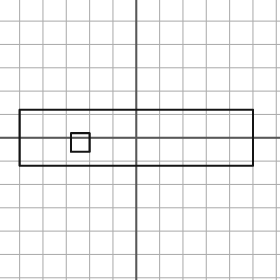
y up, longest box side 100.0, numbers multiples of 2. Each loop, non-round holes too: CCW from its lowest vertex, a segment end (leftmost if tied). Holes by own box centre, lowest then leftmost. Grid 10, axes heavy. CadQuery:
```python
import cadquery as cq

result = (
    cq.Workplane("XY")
    .moveTo(-50.0, -12.0)
    .lineTo(50.0, -12.0)
    .lineTo(50.0, 12.0)
    .lineTo(-50.0, 12.0)
    .close()
    .moveTo(-28.0, -6.0)
    .lineTo(-20.0, -6.0)
    .lineTo(-20.0, 2.0)
    .lineTo(-28.0, 2.0)
    .close()
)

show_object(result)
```